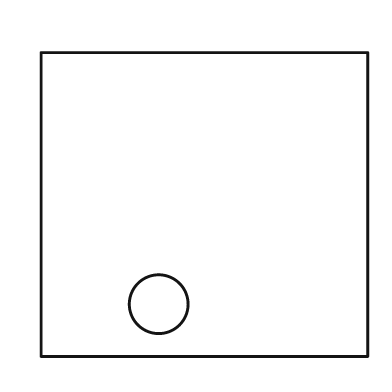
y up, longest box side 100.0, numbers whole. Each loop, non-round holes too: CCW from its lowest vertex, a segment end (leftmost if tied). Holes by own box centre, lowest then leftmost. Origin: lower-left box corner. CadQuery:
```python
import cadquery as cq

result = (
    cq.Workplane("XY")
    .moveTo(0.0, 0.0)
    .lineTo(100.0, 0.0)
    .lineTo(100.0, 93.0)
    .lineTo(0.0, 93.0)
    .close()
    .moveTo(36.0, 16.0)
    .circle(9.0)
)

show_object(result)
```